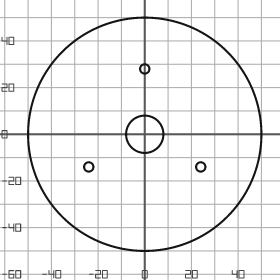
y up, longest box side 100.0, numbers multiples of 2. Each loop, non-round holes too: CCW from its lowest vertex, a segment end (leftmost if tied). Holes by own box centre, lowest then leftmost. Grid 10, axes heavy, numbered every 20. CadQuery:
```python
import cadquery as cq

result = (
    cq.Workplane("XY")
    .moveTo(0.0, 0.0)
    .circle(50.0)
    .moveTo(-24.0, -14.0)
    .circle(2.0)
    .moveTo(24.0, -14.0)
    .circle(2.0)
    .moveTo(0.0, 0.0)
    .circle(8.0)
    .moveTo(0.0, 28.0)
    .circle(2.0)
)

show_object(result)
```